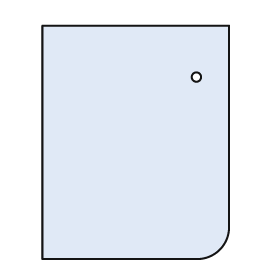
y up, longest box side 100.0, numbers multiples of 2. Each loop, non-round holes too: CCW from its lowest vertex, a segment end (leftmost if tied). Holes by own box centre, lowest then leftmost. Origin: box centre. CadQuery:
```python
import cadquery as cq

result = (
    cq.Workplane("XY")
    .moveTo(-40.0, -50.0)
    .lineTo(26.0, -50.0)
    .threePointArc((36.0, -46.0), (40.0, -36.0))
    .lineTo(40.0, 50.0)
    .lineTo(-40.0, 50.0)
    .close()
    .moveTo(26.0, 28.0)
    .circle(2.0)
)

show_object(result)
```